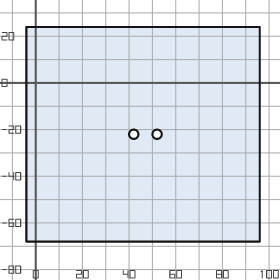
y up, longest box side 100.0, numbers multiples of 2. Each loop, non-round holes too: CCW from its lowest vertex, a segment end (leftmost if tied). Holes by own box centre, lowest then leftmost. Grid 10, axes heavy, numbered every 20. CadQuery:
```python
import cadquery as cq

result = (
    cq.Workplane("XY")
    .moveTo(-4.0, -68.0)
    .lineTo(96.0, -68.0)
    .lineTo(96.0, 24.0)
    .lineTo(-4.0, 24.0)
    .close()
    .moveTo(42.0, -22.0)
    .circle(2.0)
    .moveTo(52.0, -22.0)
    .circle(2.0)
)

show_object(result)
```